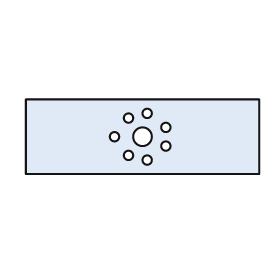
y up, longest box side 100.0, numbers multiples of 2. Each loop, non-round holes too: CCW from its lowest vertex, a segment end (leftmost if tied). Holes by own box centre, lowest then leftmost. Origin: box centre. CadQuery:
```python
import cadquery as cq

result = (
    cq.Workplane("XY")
    .moveTo(-50.0, -16.0)
    .lineTo(50.0, -16.0)
    .lineTo(50.0, 16.0)
    .lineTo(-50.0, 16.0)
    .close()
    .moveTo(2.0, -10.0)
    .circle(2.0)
    .moveTo(-6.0, -8.0)
    .circle(2.0)
    .moveTo(10.0, -4.0)
    .circle(2.0)
    .moveTo(-12.0, 0.0)
    .circle(2.0)
    .moveTo(0.0, 0.0)
    .circle(4.0)
    .moveTo(10.0, 4.0)
    .circle(2.0)
    .moveTo(-6.0, 8.0)
    .circle(2.0)
    .moveTo(2.0, 10.0)
    .circle(2.0)
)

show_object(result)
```